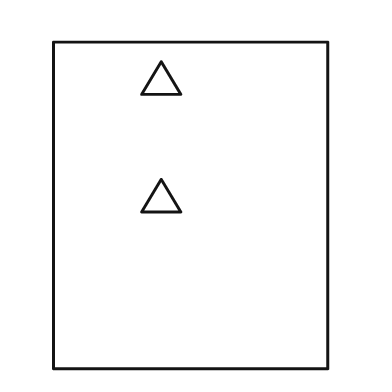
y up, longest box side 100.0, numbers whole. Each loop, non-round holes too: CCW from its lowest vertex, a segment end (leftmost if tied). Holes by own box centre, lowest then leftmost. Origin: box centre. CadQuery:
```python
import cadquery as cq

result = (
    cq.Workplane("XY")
    .moveTo(-42.0, -50.0)
    .lineTo(42.0, -50.0)
    .lineTo(42.0, 50.0)
    .lineTo(-42.0, 50.0)
    .close()
    .moveTo(-15.0, -2.0)
    .lineTo(-3.0, -2.0)
    .lineTo(-9.0, 8.0)
    .close()
    .moveTo(-15.0, 34.0)
    .lineTo(-3.0, 34.0)
    .lineTo(-9.0, 44.0)
    .close()
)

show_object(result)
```